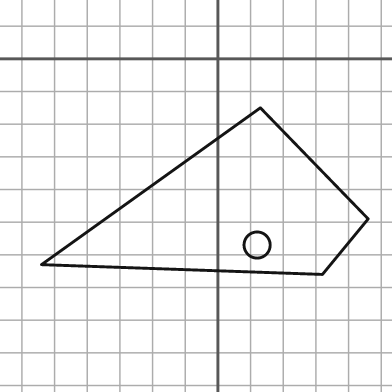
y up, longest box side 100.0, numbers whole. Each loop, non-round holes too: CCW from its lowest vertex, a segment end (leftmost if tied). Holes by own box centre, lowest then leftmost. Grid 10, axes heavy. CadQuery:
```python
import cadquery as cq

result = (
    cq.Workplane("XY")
    .moveTo(32.0, -66.0)
    .lineTo(46.0, -49.0)
    .lineTo(13.0, -15.0)
    .lineTo(-54.0, -63.0)
    .close()
    .moveTo(12.0, -57.0)
    .circle(4.0)
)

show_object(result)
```